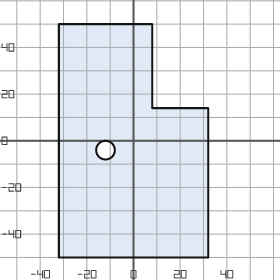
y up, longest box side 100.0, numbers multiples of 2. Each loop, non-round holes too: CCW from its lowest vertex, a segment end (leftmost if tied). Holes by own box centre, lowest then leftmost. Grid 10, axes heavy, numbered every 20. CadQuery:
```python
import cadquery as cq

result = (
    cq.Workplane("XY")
    .moveTo(-32.0, -50.0)
    .lineTo(32.0, -50.0)
    .lineTo(32.0, 14.0)
    .lineTo(8.0, 14.0)
    .lineTo(8.0, 50.0)
    .lineTo(-32.0, 50.0)
    .close()
    .moveTo(-12.0, -4.0)
    .circle(4.0)
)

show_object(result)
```